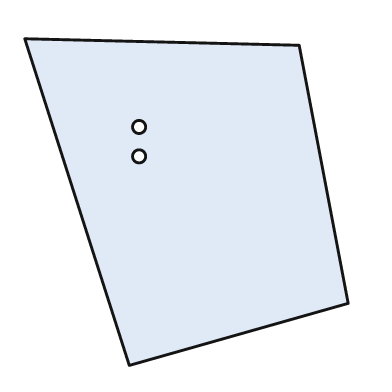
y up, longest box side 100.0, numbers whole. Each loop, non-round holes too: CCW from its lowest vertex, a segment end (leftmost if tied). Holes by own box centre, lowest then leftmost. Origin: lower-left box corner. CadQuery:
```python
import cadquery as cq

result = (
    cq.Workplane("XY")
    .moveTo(32.0, 0.0)
    .lineTo(99.0, 19.0)
    .lineTo(84.0, 98.0)
    .lineTo(0.0, 100.0)
    .close()
    .moveTo(35.0, 64.0)
    .circle(2.0)
    .moveTo(35.0, 73.0)
    .circle(2.0)
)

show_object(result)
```